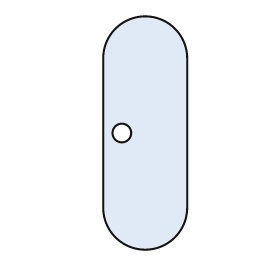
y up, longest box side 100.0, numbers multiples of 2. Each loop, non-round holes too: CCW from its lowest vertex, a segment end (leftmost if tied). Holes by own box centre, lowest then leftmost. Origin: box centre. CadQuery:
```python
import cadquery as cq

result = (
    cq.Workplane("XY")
    .moveTo(-18.0, -32.0)
    .threePointArc((0.0, -50.0), (18.0, -32.0))
    .lineTo(18.0, 32.0)
    .threePointArc((0.0, 50.0), (-18.0, 32.0))
    .close()
    .moveTo(-10.0, 0.0)
    .circle(4.0)
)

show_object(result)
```